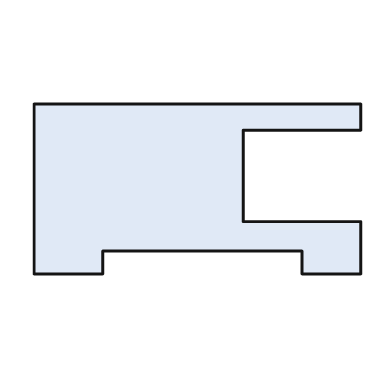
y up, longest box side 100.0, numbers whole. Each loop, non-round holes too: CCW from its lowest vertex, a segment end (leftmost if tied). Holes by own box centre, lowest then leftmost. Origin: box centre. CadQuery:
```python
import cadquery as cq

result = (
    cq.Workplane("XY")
    .moveTo(-50.0, -26.0)
    .lineTo(-29.0, -26.0)
    .lineTo(-29.0, -19.0)
    .lineTo(32.0, -19.0)
    .lineTo(32.0, -26.0)
    .lineTo(50.0, -26.0)
    .lineTo(50.0, -10.0)
    .lineTo(14.0, -10.0)
    .lineTo(14.0, 18.0)
    .lineTo(50.0, 18.0)
    .lineTo(50.0, 26.0)
    .lineTo(-50.0, 26.0)
    .close()
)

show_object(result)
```